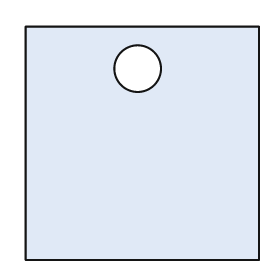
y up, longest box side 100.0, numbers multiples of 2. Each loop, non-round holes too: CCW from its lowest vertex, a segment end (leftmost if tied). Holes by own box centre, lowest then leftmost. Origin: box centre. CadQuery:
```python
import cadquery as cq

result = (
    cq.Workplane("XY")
    .moveTo(-50.0, -50.0)
    .lineTo(50.0, -50.0)
    .lineTo(50.0, 50.0)
    .lineTo(-50.0, 50.0)
    .close()
    .moveTo(-2.0, 32.0)
    .circle(10.0)
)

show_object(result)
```